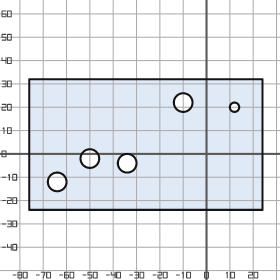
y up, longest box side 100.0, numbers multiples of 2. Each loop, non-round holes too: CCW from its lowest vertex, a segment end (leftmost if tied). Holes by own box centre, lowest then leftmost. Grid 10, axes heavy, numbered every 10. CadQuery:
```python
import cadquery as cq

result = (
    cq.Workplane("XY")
    .moveTo(-76.0, -24.0)
    .lineTo(24.0, -24.0)
    .lineTo(24.0, 32.0)
    .lineTo(-76.0, 32.0)
    .close()
    .moveTo(-64.0, -12.0)
    .circle(4.0)
    .moveTo(-34.0, -4.0)
    .circle(4.0)
    .moveTo(-50.0, -2.0)
    .circle(4.0)
    .moveTo(12.0, 20.0)
    .circle(2.0)
    .moveTo(-10.0, 22.0)
    .circle(4.0)
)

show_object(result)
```